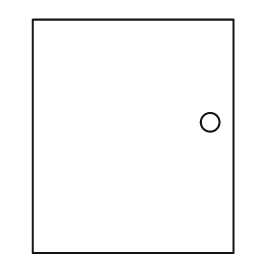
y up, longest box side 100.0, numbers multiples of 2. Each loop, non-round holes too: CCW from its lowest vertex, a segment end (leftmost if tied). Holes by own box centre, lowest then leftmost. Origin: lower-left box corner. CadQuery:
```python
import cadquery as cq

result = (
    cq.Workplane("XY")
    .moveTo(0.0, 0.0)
    .lineTo(86.0, 0.0)
    .lineTo(86.0, 100.0)
    .lineTo(0.0, 100.0)
    .close()
    .moveTo(76.0, 56.0)
    .circle(4.0)
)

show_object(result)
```